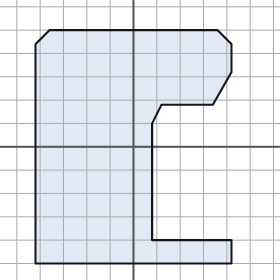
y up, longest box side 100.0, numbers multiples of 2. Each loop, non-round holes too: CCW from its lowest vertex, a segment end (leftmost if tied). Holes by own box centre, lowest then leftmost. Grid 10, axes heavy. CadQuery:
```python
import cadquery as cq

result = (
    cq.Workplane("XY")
    .moveTo(-42.0, -50.0)
    .lineTo(42.0, -50.0)
    .lineTo(42.0, -40.0)
    .lineTo(8.0, -40.0)
    .lineTo(8.0, 10.0)
    .lineTo(12.0, 18.0)
    .lineTo(34.0, 18.0)
    .lineTo(42.0, 32.0)
    .lineTo(42.0, 44.0)
    .lineTo(36.0, 50.0)
    .lineTo(-36.0, 50.0)
    .lineTo(-42.0, 44.0)
    .close()
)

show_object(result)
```